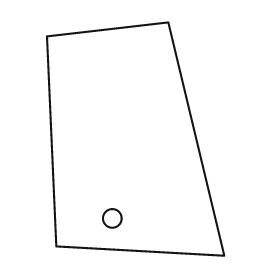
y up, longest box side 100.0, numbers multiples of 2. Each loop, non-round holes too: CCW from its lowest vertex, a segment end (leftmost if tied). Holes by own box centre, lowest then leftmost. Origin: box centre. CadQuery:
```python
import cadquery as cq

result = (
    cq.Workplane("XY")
    .moveTo(38.0, -50.0)
    .lineTo(14.0, 50.0)
    .lineTo(-38.0, 44.0)
    .lineTo(-34.0, -46.0)
    .close()
    .moveTo(-10.0, -34.0)
    .circle(4.0)
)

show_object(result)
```